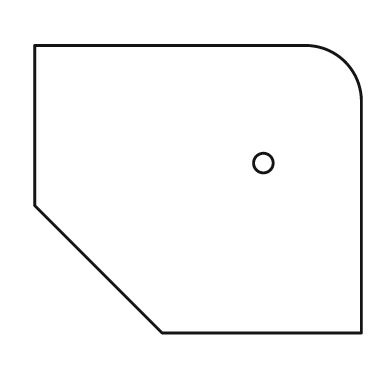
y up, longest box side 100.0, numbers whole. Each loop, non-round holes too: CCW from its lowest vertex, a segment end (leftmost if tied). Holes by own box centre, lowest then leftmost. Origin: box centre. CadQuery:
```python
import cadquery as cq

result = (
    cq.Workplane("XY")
    .moveTo(-11.0, -44.0)
    .lineTo(50.0, -44.0)
    .lineTo(50.0, 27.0)
    .threePointArc((45.0, 39.0), (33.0, 44.0))
    .lineTo(-50.0, 44.0)
    .lineTo(-50.0, -5.0)
    .close()
    .moveTo(20.0, 8.0)
    .circle(3.0)
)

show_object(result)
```